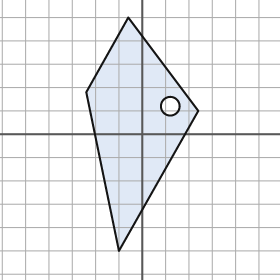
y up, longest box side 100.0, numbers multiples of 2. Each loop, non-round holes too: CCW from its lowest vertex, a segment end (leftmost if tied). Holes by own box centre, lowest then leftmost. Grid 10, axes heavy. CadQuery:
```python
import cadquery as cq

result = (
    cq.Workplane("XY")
    .moveTo(-10.0, -50.0)
    .lineTo(24.0, 10.0)
    .lineTo(-6.0, 50.0)
    .lineTo(-24.0, 18.0)
    .close()
    .moveTo(12.0, 12.0)
    .circle(4.0)
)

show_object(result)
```